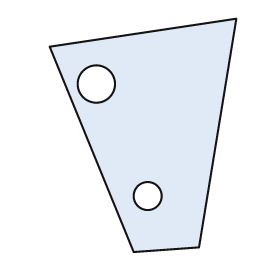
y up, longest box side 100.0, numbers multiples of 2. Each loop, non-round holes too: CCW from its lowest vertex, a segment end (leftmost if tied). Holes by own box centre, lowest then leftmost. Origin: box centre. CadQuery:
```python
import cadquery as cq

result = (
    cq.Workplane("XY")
    .moveTo(-4.0, -50.0)
    .lineTo(24.0, -48.0)
    .lineTo(40.0, 50.0)
    .lineTo(-40.0, 38.0)
    .close()
    .moveTo(2.0, -26.0)
    .circle(6.0)
    .moveTo(-20.0, 22.0)
    .circle(8.0)
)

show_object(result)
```